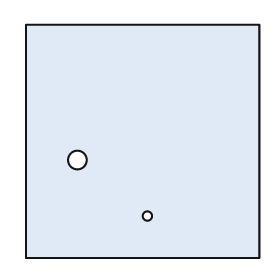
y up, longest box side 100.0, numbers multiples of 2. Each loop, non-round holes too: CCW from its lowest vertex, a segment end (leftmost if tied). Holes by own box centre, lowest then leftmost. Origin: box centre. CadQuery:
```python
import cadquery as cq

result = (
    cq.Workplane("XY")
    .moveTo(-50.0, -50.0)
    .lineTo(50.0, -50.0)
    .lineTo(50.0, 50.0)
    .lineTo(-50.0, 50.0)
    .close()
    .moveTo(2.0, -32.0)
    .circle(2.0)
    .moveTo(-28.0, -8.0)
    .circle(4.0)
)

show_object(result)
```